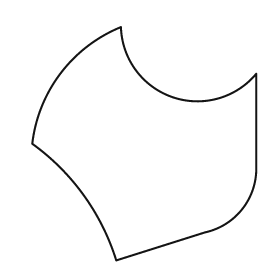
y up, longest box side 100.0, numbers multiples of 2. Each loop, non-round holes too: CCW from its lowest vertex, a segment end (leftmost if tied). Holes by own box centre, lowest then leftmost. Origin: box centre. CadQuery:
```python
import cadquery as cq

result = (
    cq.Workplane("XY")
    .moveTo(-12.0, -50.0)
    .lineTo(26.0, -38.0)
    .threePointArc((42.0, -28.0), (48.0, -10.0))
    .lineTo(48.0, 30.0)
    .threePointArc((12.0, 20.0), (-10.0, 50.0))
    .threePointArc((-36.0, 30.0), (-48.0, 0.0))
    .threePointArc((-26.0, -22.0), (-12.0, -50.0))
    .close()
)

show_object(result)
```